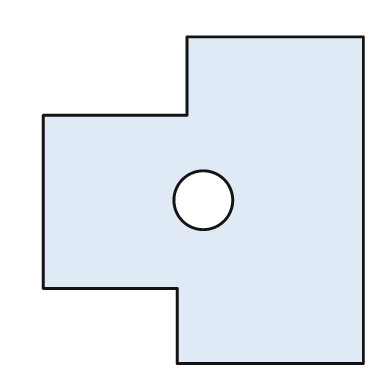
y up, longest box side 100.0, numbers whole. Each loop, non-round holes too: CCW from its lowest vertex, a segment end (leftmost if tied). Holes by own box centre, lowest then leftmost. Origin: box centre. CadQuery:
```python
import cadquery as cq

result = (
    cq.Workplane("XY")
    .moveTo(-8.0, -50.0)
    .lineTo(49.0, -50.0)
    .lineTo(49.0, 50.0)
    .lineTo(-5.0, 50.0)
    .lineTo(-5.0, 26.0)
    .lineTo(-49.0, 26.0)
    .lineTo(-49.0, -27.0)
    .lineTo(-8.0, -27.0)
    .close()
    .moveTo(0.0, 0.0)
    .circle(9.0)
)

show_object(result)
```